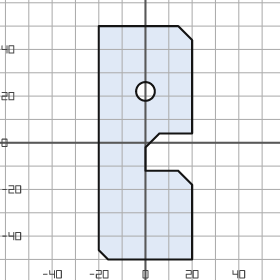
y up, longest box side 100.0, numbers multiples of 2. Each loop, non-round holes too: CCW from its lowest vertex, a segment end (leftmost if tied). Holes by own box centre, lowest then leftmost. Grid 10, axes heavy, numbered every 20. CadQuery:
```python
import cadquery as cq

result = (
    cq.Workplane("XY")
    .moveTo(-16.0, -50.0)
    .lineTo(20.0, -50.0)
    .lineTo(20.0, -18.0)
    .lineTo(14.0, -12.0)
    .lineTo(0.0, -12.0)
    .lineTo(0.0, -2.0)
    .lineTo(6.0, 4.0)
    .lineTo(20.0, 4.0)
    .lineTo(20.0, 44.0)
    .lineTo(14.0, 50.0)
    .lineTo(-20.0, 50.0)
    .lineTo(-20.0, -46.0)
    .close()
    .moveTo(0.0, 22.0)
    .circle(4.0)
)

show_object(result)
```